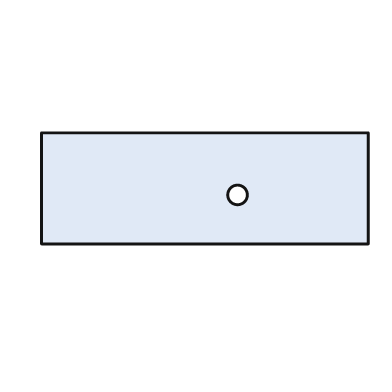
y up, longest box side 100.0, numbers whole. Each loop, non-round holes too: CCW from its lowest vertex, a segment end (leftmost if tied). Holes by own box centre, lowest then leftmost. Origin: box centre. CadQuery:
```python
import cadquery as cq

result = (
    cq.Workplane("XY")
    .moveTo(-50.0, -17.0)
    .lineTo(50.0, -17.0)
    .lineTo(50.0, 17.0)
    .lineTo(-50.0, 17.0)
    .close()
    .moveTo(10.0, -2.0)
    .circle(3.0)
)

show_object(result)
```